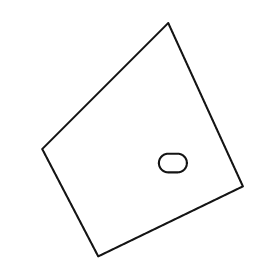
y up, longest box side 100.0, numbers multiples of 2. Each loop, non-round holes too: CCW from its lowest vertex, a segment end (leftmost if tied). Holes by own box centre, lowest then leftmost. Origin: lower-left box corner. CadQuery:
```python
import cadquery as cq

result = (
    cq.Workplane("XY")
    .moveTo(24.0, 0.0)
    .lineTo(86.0, 30.0)
    .lineTo(54.0, 100.0)
    .lineTo(0.0, 46.0)
    .close()
    .moveTo(54.0, 36.0)
    .lineTo(58.0, 36.0)
    .threePointArc((62.0, 40.0), (58.0, 44.0))
    .lineTo(54.0, 44.0)
    .threePointArc((50.0, 40.0), (54.0, 36.0))
    .close()
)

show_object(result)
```